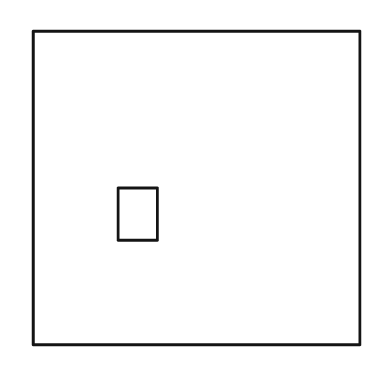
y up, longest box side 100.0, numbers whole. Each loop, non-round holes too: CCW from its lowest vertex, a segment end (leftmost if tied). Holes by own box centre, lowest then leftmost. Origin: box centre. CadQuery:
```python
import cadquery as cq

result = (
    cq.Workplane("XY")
    .moveTo(-50.0, -48.0)
    .lineTo(50.0, -48.0)
    .lineTo(50.0, 48.0)
    .lineTo(-50.0, 48.0)
    .close()
    .moveTo(-24.0, -16.0)
    .lineTo(-12.0, -16.0)
    .lineTo(-12.0, 0.0)
    .lineTo(-24.0, 0.0)
    .close()
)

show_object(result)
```